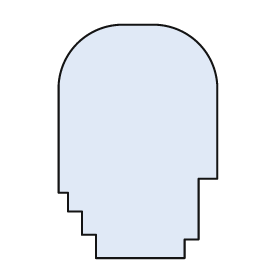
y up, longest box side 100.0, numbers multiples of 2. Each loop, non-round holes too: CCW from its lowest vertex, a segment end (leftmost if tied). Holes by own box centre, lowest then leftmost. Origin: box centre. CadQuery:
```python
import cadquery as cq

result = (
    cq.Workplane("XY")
    .moveTo(-18.0, -50.0)
    .lineTo(20.0, -50.0)
    .lineTo(20.0, -42.0)
    .lineTo(26.0, -42.0)
    .lineTo(26.0, -16.0)
    .lineTo(34.0, -16.0)
    .lineTo(34.0, 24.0)
    .threePointArc((26.0, 42.0), (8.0, 50.0))
    .lineTo(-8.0, 50.0)
    .threePointArc((-26.0, 42.0), (-34.0, 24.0))
    .lineTo(-34.0, -22.0)
    .lineTo(-30.0, -22.0)
    .lineTo(-30.0, -30.0)
    .lineTo(-24.0, -30.0)
    .lineTo(-24.0, -40.0)
    .lineTo(-18.0, -40.0)
    .close()
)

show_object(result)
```